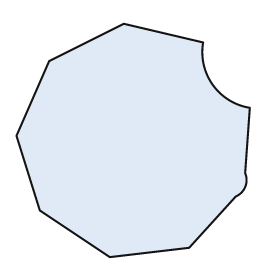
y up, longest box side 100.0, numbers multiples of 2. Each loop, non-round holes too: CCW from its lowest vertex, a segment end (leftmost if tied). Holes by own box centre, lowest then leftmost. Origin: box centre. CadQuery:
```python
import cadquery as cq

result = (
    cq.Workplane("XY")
    .moveTo(-10.0, -50.0)
    .lineTo(24.0, -46.0)
    .lineTo(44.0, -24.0)
    .threePointArc((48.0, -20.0), (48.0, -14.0))
    .lineTo(50.0, 14.0)
    .threePointArc((34.0, 24.0), (30.0, 42.0))
    .lineTo(-4.0, 50.0)
    .lineTo(-36.0, 34.0)
    .lineTo(-50.0, 2.0)
    .lineTo(-40.0, -30.0)
    .close()
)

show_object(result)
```